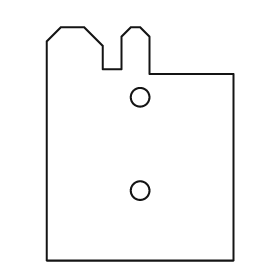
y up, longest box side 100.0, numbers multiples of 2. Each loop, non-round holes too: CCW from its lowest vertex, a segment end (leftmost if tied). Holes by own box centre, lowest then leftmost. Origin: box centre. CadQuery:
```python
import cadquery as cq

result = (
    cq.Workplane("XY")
    .moveTo(-40.0, -50.0)
    .lineTo(40.0, -50.0)
    .lineTo(40.0, 30.0)
    .lineTo(4.0, 30.0)
    .lineTo(4.0, 46.0)
    .lineTo(0.0, 50.0)
    .lineTo(-4.0, 50.0)
    .lineTo(-8.0, 46.0)
    .lineTo(-8.0, 32.0)
    .lineTo(-16.0, 32.0)
    .lineTo(-16.0, 42.0)
    .lineTo(-24.0, 50.0)
    .lineTo(-34.0, 50.0)
    .lineTo(-40.0, 44.0)
    .close()
    .moveTo(0.0, -20.0)
    .circle(4.0)
    .moveTo(0.0, 20.0)
    .circle(4.0)
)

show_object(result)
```